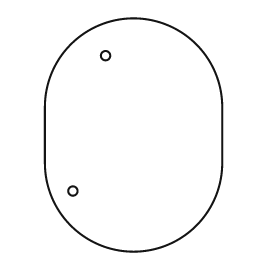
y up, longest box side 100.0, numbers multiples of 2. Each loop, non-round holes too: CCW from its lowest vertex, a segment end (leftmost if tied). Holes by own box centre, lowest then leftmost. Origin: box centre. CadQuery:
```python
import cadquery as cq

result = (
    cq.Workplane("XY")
    .moveTo(-38.0, -12.0)
    .threePointArc((0.0, -50.0), (38.0, -12.0))
    .lineTo(38.0, 12.0)
    .threePointArc((0.0, 50.0), (-38.0, 12.0))
    .close()
    .moveTo(-26.0, -24.0)
    .circle(2.0)
    .moveTo(-12.0, 34.0)
    .circle(2.0)
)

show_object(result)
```